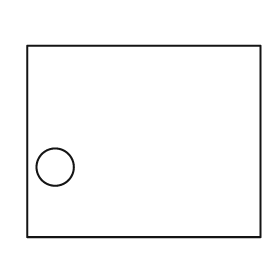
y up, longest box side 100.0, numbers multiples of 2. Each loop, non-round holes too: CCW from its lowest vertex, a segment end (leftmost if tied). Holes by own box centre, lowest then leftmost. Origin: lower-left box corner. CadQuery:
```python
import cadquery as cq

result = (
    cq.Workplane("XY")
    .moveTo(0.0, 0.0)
    .lineTo(100.0, 0.0)
    .lineTo(100.0, 82.0)
    .lineTo(0.0, 82.0)
    .close()
    .moveTo(12.0, 30.0)
    .circle(8.0)
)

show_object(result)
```